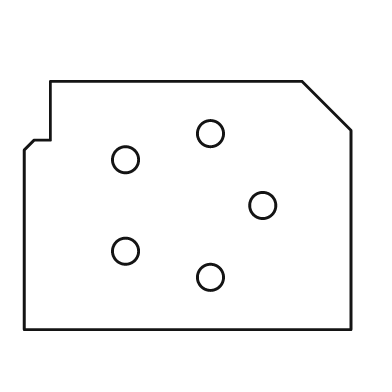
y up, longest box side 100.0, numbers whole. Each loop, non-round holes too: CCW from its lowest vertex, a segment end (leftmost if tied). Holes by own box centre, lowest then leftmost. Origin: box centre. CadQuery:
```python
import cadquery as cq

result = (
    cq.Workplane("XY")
    .moveTo(-50.0, -38.0)
    .lineTo(50.0, -38.0)
    .lineTo(50.0, 23.0)
    .lineTo(35.0, 38.0)
    .lineTo(-42.0, 38.0)
    .lineTo(-42.0, 20.0)
    .lineTo(-47.0, 20.0)
    .lineTo(-50.0, 17.0)
    .close()
    .moveTo(7.0, -22.0)
    .circle(4.0)
    .moveTo(-19.0, -14.0)
    .circle(4.0)
    .moveTo(23.0, 0.0)
    .circle(4.0)
    .moveTo(-19.0, 14.0)
    .circle(4.0)
    .moveTo(7.0, 22.0)
    .circle(4.0)
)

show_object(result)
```